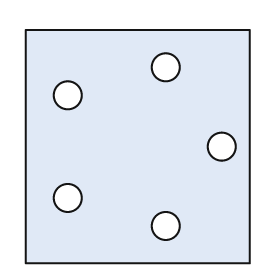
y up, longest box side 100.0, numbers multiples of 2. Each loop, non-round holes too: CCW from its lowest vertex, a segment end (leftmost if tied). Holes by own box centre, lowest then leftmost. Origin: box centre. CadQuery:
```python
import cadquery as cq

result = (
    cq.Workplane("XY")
    .moveTo(-48.0, -50.0)
    .lineTo(48.0, -50.0)
    .lineTo(48.0, 50.0)
    .lineTo(-48.0, 50.0)
    .close()
    .moveTo(12.0, -34.0)
    .circle(6.0)
    .moveTo(-30.0, -22.0)
    .circle(6.0)
    .moveTo(36.0, 0.0)
    .circle(6.0)
    .moveTo(-30.0, 22.0)
    .circle(6.0)
    .moveTo(12.0, 34.0)
    .circle(6.0)
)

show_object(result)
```